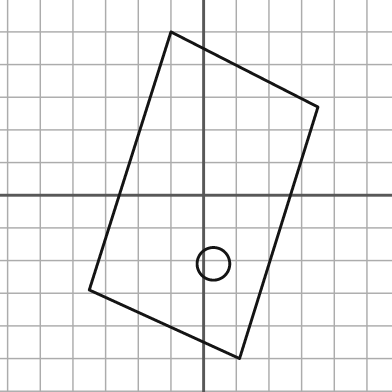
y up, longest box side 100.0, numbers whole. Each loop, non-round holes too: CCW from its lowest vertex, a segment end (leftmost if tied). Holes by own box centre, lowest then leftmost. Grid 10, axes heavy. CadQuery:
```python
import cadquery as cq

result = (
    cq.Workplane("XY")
    .moveTo(11.0, -50.0)
    .lineTo(35.0, 27.0)
    .lineTo(-10.0, 50.0)
    .lineTo(-35.0, -29.0)
    .close()
    .moveTo(3.0, -21.0)
    .circle(5.0)
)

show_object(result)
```